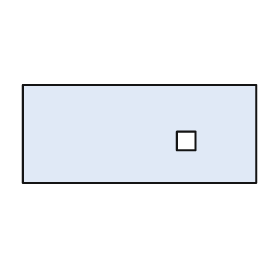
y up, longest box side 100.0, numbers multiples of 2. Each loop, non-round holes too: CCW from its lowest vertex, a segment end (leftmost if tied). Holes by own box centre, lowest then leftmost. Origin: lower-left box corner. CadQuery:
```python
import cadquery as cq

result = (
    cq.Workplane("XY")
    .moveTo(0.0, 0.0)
    .lineTo(100.0, 0.0)
    .lineTo(100.0, 42.0)
    .lineTo(0.0, 42.0)
    .close()
    .moveTo(66.0, 14.0)
    .lineTo(74.0, 14.0)
    .lineTo(74.0, 22.0)
    .lineTo(66.0, 22.0)
    .close()
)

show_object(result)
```